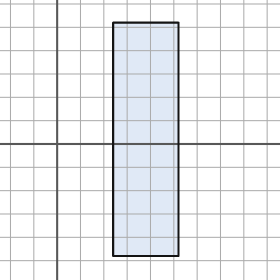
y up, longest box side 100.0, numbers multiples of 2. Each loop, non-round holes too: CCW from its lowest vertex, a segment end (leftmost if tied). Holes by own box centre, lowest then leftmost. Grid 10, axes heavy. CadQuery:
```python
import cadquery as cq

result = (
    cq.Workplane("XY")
    .moveTo(24.0, -48.0)
    .lineTo(52.0, -48.0)
    .lineTo(52.0, 52.0)
    .lineTo(24.0, 52.0)
    .close()
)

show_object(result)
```